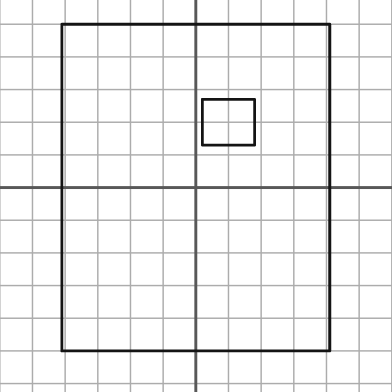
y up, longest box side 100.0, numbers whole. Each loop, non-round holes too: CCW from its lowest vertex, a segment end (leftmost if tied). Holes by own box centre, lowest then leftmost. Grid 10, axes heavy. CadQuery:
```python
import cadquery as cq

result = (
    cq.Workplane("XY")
    .moveTo(-41.0, -50.0)
    .lineTo(41.0, -50.0)
    .lineTo(41.0, 50.0)
    .lineTo(-41.0, 50.0)
    .close()
    .moveTo(2.0, 13.0)
    .lineTo(18.0, 13.0)
    .lineTo(18.0, 27.0)
    .lineTo(2.0, 27.0)
    .close()
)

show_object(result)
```